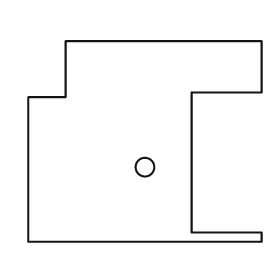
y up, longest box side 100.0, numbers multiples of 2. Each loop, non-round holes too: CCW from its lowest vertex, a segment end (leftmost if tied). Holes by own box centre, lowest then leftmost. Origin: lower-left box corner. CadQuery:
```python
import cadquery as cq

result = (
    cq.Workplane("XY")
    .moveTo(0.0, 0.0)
    .lineTo(100.0, 0.0)
    .lineTo(100.0, 4.0)
    .lineTo(70.0, 4.0)
    .lineTo(70.0, 64.0)
    .lineTo(100.0, 64.0)
    .lineTo(100.0, 86.0)
    .lineTo(16.0, 86.0)
    .lineTo(16.0, 62.0)
    .lineTo(0.0, 62.0)
    .close()
    .moveTo(50.0, 32.0)
    .circle(4.0)
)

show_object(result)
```